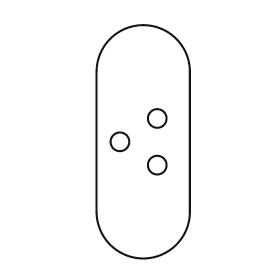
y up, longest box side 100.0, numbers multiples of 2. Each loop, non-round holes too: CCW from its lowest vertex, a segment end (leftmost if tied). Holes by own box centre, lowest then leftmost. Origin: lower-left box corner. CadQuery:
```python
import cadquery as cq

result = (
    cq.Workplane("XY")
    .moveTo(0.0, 20.0)
    .threePointArc((20.0, 0.0), (40.0, 20.0))
    .lineTo(40.0, 80.0)
    .threePointArc((20.0, 100.0), (0.0, 80.0))
    .close()
    .moveTo(26.0, 40.0)
    .circle(4.0)
    .moveTo(10.0, 50.0)
    .circle(4.0)
    .moveTo(26.0, 60.0)
    .circle(4.0)
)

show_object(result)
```